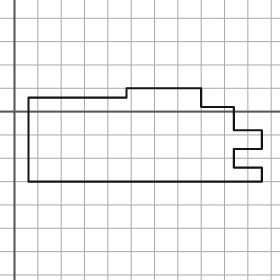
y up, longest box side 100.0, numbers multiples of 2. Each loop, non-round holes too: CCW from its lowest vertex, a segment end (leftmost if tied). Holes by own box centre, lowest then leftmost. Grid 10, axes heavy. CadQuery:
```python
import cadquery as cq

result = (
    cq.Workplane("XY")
    .moveTo(6.0, -30.0)
    .lineTo(106.0, -30.0)
    .lineTo(106.0, -24.0)
    .lineTo(94.0, -24.0)
    .lineTo(94.0, -16.0)
    .lineTo(106.0, -16.0)
    .lineTo(106.0, -8.0)
    .lineTo(94.0, -8.0)
    .lineTo(94.0, 2.0)
    .lineTo(80.0, 2.0)
    .lineTo(80.0, 10.0)
    .lineTo(48.0, 10.0)
    .lineTo(48.0, 6.0)
    .lineTo(6.0, 6.0)
    .close()
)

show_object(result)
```